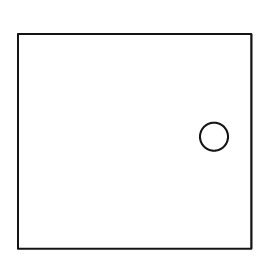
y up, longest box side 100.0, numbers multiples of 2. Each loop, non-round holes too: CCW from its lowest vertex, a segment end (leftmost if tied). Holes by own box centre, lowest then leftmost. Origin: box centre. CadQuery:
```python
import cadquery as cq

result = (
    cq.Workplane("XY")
    .moveTo(-50.0, -46.0)
    .lineTo(50.0, -46.0)
    .lineTo(50.0, 46.0)
    .lineTo(-50.0, 46.0)
    .close()
    .moveTo(34.0, 2.0)
    .circle(6.0)
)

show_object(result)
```